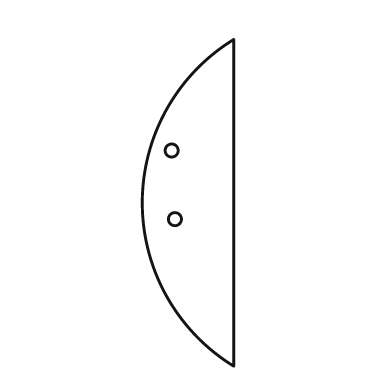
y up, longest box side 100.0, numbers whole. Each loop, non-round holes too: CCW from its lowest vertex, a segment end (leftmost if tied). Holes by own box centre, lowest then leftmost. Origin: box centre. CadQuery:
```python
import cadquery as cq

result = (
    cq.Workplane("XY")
    .moveTo(14.0, -50.0)
    .lineTo(14.0, 50.0)
    .threePointArc((-14.0, 0.0), (14.0, -50.0))
    .close()
    .moveTo(-4.0, -5.0)
    .circle(2.0)
    .moveTo(-5.0, 16.0)
    .circle(2.0)
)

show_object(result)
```